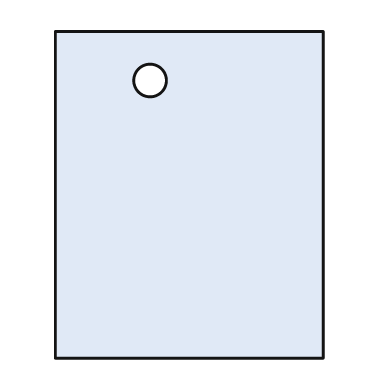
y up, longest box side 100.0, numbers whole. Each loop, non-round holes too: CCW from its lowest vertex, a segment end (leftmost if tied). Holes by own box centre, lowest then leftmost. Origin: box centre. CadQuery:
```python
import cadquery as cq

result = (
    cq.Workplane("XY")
    .moveTo(-41.0, -50.0)
    .lineTo(41.0, -50.0)
    .lineTo(41.0, 50.0)
    .lineTo(-41.0, 50.0)
    .close()
    .moveTo(-12.0, 35.0)
    .circle(5.0)
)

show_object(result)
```